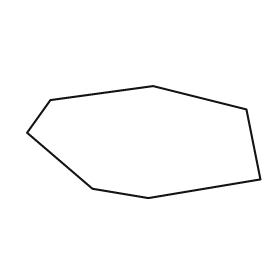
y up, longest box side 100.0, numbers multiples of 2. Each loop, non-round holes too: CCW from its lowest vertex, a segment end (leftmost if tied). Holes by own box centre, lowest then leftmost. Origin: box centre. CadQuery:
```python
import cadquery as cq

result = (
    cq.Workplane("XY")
    .moveTo(2.0, -24.0)
    .lineTo(50.0, -16.0)
    .lineTo(44.0, 14.0)
    .lineTo(4.0, 24.0)
    .lineTo(-40.0, 18.0)
    .lineTo(-50.0, 4.0)
    .lineTo(-22.0, -20.0)
    .close()
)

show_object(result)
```